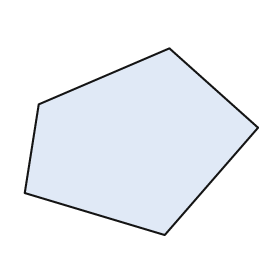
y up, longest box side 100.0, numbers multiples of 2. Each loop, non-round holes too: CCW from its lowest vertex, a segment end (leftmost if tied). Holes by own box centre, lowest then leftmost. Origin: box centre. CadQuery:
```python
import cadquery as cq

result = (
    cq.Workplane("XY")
    .moveTo(10.0, -40.0)
    .lineTo(50.0, 6.0)
    .lineTo(12.0, 40.0)
    .lineTo(-44.0, 16.0)
    .lineTo(-50.0, -22.0)
    .close()
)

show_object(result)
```